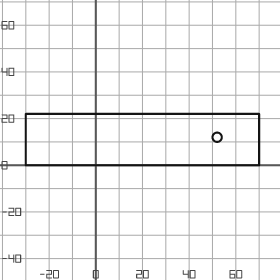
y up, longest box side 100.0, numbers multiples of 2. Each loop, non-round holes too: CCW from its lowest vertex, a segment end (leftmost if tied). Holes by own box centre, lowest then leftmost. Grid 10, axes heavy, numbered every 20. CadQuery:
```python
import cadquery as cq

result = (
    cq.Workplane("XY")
    .moveTo(-30.0, 0.0)
    .lineTo(70.0, 0.0)
    .lineTo(70.0, 22.0)
    .lineTo(-30.0, 22.0)
    .close()
    .moveTo(52.0, 12.0)
    .circle(2.0)
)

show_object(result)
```